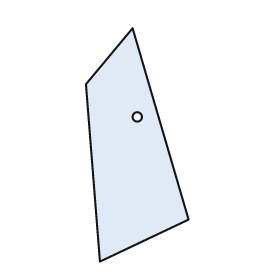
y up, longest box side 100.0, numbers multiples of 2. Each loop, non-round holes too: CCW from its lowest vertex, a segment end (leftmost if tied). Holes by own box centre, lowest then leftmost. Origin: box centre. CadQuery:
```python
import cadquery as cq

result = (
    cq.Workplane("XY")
    .moveTo(-16.0, -50.0)
    .lineTo(22.0, -32.0)
    .lineTo(-2.0, 50.0)
    .lineTo(-22.0, 26.0)
    .close()
    .moveTo(0.0, 12.0)
    .circle(2.0)
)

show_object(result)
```